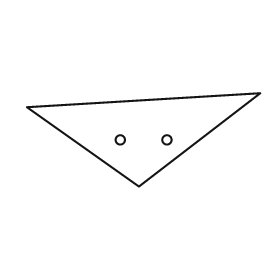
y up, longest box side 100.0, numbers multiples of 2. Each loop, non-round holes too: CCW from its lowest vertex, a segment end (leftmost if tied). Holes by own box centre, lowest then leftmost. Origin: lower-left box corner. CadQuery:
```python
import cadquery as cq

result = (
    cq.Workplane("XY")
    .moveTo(48.0, 0.0)
    .lineTo(100.0, 40.0)
    .lineTo(0.0, 34.0)
    .close()
    .moveTo(40.0, 20.0)
    .circle(2.0)
    .moveTo(60.0, 20.0)
    .circle(2.0)
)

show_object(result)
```